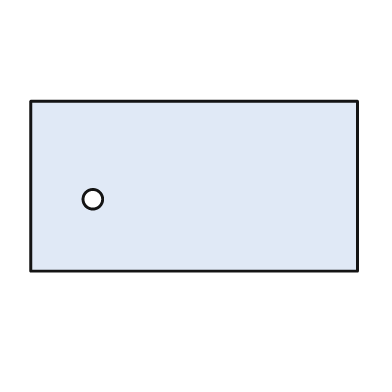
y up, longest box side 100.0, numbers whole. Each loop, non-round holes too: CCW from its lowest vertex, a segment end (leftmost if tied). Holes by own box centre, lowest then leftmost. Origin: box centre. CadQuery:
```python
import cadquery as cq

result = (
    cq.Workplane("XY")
    .moveTo(-50.0, -26.0)
    .lineTo(50.0, -26.0)
    .lineTo(50.0, 26.0)
    .lineTo(-50.0, 26.0)
    .close()
    .moveTo(-31.0, -4.0)
    .circle(3.0)
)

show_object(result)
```